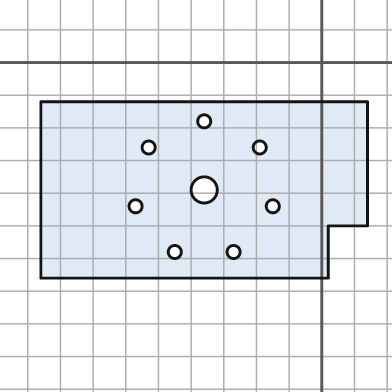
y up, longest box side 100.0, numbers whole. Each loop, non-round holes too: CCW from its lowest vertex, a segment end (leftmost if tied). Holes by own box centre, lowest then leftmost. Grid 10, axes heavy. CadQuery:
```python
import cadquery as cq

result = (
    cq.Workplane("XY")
    .moveTo(-86.0, -66.0)
    .lineTo(2.0, -66.0)
    .lineTo(2.0, -50.0)
    .lineTo(14.0, -50.0)
    .lineTo(14.0, -12.0)
    .lineTo(-86.0, -12.0)
    .close()
    .moveTo(-45.0, -58.0)
    .circle(2.0)
    .moveTo(-27.0, -58.0)
    .circle(2.0)
    .moveTo(-57.0, -44.0)
    .circle(2.0)
    .moveTo(-15.0, -44.0)
    .circle(2.0)
    .moveTo(-36.0, -39.0)
    .circle(4.0)
    .moveTo(-53.0, -26.0)
    .circle(2.0)
    .moveTo(-19.0, -26.0)
    .circle(2.0)
    .moveTo(-36.0, -18.0)
    .circle(2.0)
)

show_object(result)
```